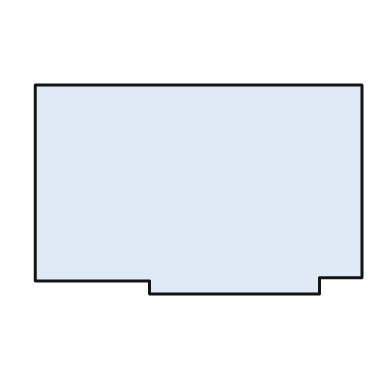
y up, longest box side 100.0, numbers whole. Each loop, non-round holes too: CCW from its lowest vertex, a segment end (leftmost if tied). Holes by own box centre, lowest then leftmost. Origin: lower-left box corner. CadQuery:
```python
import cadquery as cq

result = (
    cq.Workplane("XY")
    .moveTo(35.0, 0.0)
    .lineTo(87.0, 0.0)
    .lineTo(87.0, 5.0)
    .lineTo(100.0, 5.0)
    .lineTo(100.0, 64.0)
    .lineTo(0.0, 64.0)
    .lineTo(0.0, 4.0)
    .lineTo(35.0, 4.0)
    .close()
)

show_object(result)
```